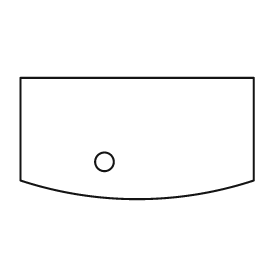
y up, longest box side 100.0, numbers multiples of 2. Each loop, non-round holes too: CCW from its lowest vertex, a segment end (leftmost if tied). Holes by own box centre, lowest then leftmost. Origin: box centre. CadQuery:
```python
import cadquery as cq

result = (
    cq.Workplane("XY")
    .moveTo(-50.0, -18.0)
    .threePointArc((0.0, -26.0), (50.0, -18.0))
    .lineTo(50.0, 26.0)
    .lineTo(-50.0, 26.0)
    .close()
    .moveTo(-14.0, -10.0)
    .circle(4.0)
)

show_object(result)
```